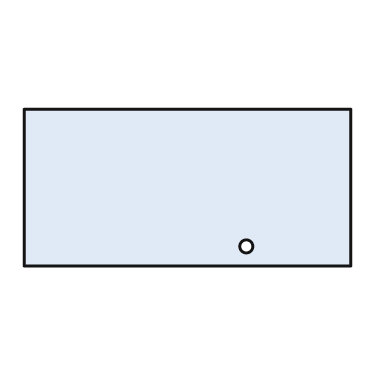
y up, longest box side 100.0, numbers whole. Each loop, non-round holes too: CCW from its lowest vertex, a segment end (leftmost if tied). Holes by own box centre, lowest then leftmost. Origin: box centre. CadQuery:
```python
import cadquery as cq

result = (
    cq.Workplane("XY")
    .moveTo(-50.0, -24.0)
    .lineTo(50.0, -24.0)
    .lineTo(50.0, 24.0)
    .lineTo(-50.0, 24.0)
    .close()
    .moveTo(18.0, -18.0)
    .circle(2.0)
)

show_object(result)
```